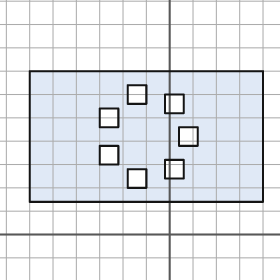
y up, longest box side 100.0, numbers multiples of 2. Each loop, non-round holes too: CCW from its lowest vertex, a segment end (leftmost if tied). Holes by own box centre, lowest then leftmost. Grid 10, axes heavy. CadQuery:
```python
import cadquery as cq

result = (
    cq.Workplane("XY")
    .moveTo(-60.0, 14.0)
    .lineTo(40.0, 14.0)
    .lineTo(40.0, 70.0)
    .lineTo(-60.0, 70.0)
    .close()
    .moveTo(-18.0, 20.0)
    .lineTo(-10.0, 20.0)
    .lineTo(-10.0, 28.0)
    .lineTo(-18.0, 28.0)
    .close()
    .moveTo(-2.0, 24.0)
    .lineTo(6.0, 24.0)
    .lineTo(6.0, 32.0)
    .lineTo(-2.0, 32.0)
    .close()
    .moveTo(-30.0, 30.0)
    .lineTo(-22.0, 30.0)
    .lineTo(-22.0, 38.0)
    .lineTo(-30.0, 38.0)
    .close()
    .moveTo(4.0, 38.0)
    .lineTo(12.0, 38.0)
    .lineTo(12.0, 46.0)
    .lineTo(4.0, 46.0)
    .close()
    .moveTo(-30.0, 46.0)
    .lineTo(-22.0, 46.0)
    .lineTo(-22.0, 54.0)
    .lineTo(-30.0, 54.0)
    .close()
    .moveTo(-2.0, 52.0)
    .lineTo(6.0, 52.0)
    .lineTo(6.0, 60.0)
    .lineTo(-2.0, 60.0)
    .close()
    .moveTo(-18.0, 56.0)
    .lineTo(-10.0, 56.0)
    .lineTo(-10.0, 64.0)
    .lineTo(-18.0, 64.0)
    .close()
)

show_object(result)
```